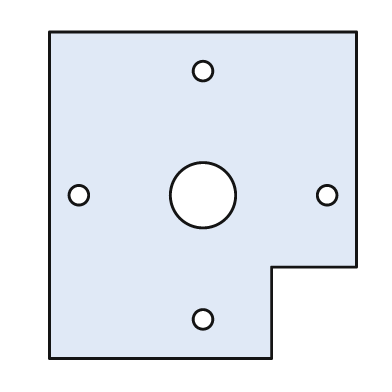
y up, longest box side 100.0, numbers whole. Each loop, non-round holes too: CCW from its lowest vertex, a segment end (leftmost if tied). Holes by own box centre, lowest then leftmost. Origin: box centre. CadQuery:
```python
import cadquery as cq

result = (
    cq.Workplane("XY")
    .moveTo(-47.0, -50.0)
    .lineTo(21.0, -50.0)
    .lineTo(21.0, -22.0)
    .lineTo(47.0, -22.0)
    .lineTo(47.0, 50.0)
    .lineTo(-47.0, 50.0)
    .close()
    .moveTo(0.0, -38.0)
    .circle(3.0)
    .moveTo(-38.0, 0.0)
    .circle(3.0)
    .moveTo(0.0, 0.0)
    .circle(10.0)
    .moveTo(38.0, 0.0)
    .circle(3.0)
    .moveTo(0.0, 38.0)
    .circle(3.0)
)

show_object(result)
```